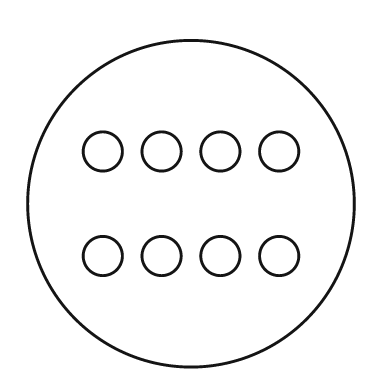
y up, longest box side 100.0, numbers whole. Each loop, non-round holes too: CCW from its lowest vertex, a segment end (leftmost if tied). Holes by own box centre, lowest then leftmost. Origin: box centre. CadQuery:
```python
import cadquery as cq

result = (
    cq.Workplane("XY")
    .moveTo(0.0, 0.0)
    .circle(50.0)
    .moveTo(-27.0, -16.0)
    .circle(6.0)
    .moveTo(-9.0, -16.0)
    .circle(6.0)
    .moveTo(9.0, -16.0)
    .circle(6.0)
    .moveTo(27.0, -16.0)
    .circle(6.0)
    .moveTo(-27.0, 16.0)
    .circle(6.0)
    .moveTo(-9.0, 16.0)
    .circle(6.0)
    .moveTo(9.0, 16.0)
    .circle(6.0)
    .moveTo(27.0, 16.0)
    .circle(6.0)
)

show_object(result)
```